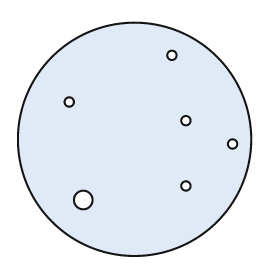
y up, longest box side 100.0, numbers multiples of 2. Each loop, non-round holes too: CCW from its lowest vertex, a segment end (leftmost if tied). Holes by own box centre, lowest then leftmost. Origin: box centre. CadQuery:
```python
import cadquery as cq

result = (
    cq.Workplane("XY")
    .moveTo(0.0, 0.0)
    .circle(50.0)
    .moveTo(-22.0, -26.0)
    .circle(4.0)
    .moveTo(22.0, -20.0)
    .circle(2.0)
    .moveTo(42.0, -2.0)
    .circle(2.0)
    .moveTo(22.0, 8.0)
    .circle(2.0)
    .moveTo(-28.0, 16.0)
    .circle(2.0)
    .moveTo(16.0, 36.0)
    .circle(2.0)
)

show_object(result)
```